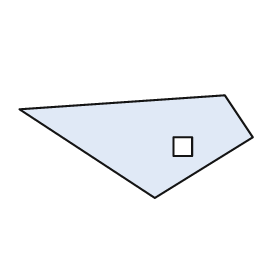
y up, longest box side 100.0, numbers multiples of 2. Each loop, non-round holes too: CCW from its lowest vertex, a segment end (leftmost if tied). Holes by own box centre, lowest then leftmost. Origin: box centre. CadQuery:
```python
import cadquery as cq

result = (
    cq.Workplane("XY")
    .moveTo(8.0, -22.0)
    .lineTo(50.0, 4.0)
    .lineTo(38.0, 22.0)
    .lineTo(-50.0, 16.0)
    .close()
    .moveTo(16.0, -4.0)
    .lineTo(24.0, -4.0)
    .lineTo(24.0, 4.0)
    .lineTo(16.0, 4.0)
    .close()
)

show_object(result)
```